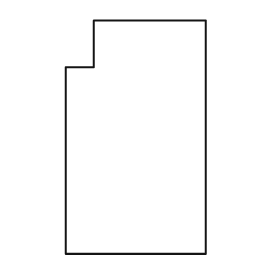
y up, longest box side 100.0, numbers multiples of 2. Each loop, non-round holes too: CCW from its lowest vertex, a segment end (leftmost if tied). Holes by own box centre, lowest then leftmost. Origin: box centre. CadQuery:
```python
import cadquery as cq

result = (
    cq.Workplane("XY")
    .moveTo(-30.0, -50.0)
    .lineTo(30.0, -50.0)
    .lineTo(30.0, 50.0)
    .lineTo(-18.0, 50.0)
    .lineTo(-18.0, 30.0)
    .lineTo(-30.0, 30.0)
    .close()
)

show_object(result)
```